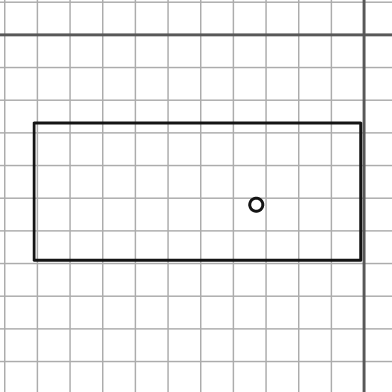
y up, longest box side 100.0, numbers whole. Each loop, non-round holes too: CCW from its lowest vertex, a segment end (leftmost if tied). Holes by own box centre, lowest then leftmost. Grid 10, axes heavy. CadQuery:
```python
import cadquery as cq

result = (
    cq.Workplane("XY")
    .moveTo(-101.0, -69.0)
    .lineTo(-1.0, -69.0)
    .lineTo(-1.0, -27.0)
    .lineTo(-101.0, -27.0)
    .close()
    .moveTo(-33.0, -52.0)
    .circle(2.0)
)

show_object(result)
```